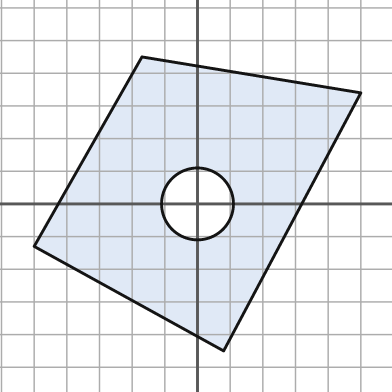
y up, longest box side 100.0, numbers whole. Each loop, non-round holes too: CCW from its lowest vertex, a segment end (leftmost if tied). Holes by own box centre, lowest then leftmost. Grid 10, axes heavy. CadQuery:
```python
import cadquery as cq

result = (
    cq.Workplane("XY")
    .moveTo(8.0, -45.0)
    .lineTo(50.0, 34.0)
    .lineTo(-17.0, 45.0)
    .lineTo(-50.0, -13.0)
    .close()
    .moveTo(0.0, 0.0)
    .circle(11.0)
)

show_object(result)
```